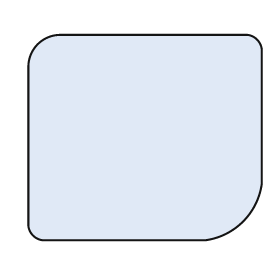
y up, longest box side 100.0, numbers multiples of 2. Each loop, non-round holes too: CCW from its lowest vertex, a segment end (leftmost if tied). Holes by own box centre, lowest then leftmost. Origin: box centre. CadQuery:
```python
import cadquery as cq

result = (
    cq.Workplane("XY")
    .moveTo(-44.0, -44.0)
    .lineTo(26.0, -44.0)
    .threePointArc((42.0, -36.0), (50.0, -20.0))
    .lineTo(50.0, 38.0)
    .threePointArc((48.0, 42.0), (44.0, 44.0))
    .lineTo(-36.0, 44.0)
    .threePointArc((-46.0, 40.0), (-50.0, 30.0))
    .lineTo(-50.0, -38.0)
    .threePointArc((-48.0, -42.0), (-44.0, -44.0))
    .close()
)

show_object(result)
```